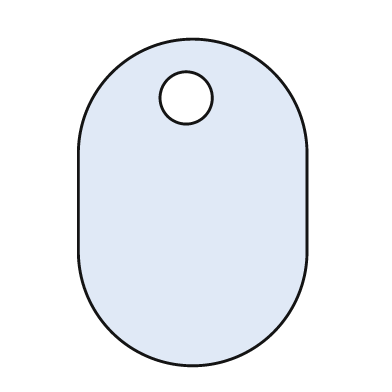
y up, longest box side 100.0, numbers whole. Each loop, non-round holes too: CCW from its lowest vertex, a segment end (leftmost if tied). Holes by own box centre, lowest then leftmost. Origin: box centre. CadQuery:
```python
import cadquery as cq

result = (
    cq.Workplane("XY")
    .moveTo(-35.0, -15.0)
    .threePointArc((0.0, -50.0), (35.0, -15.0))
    .lineTo(35.0, 15.0)
    .threePointArc((0.0, 50.0), (-35.0, 15.0))
    .close()
    .moveTo(-2.0, 32.0)
    .circle(8.0)
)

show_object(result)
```